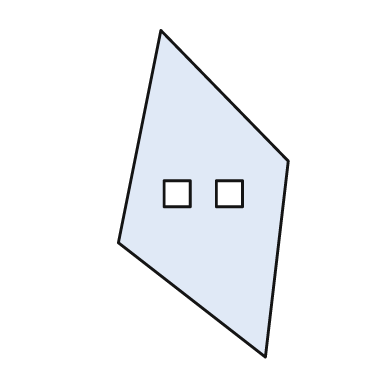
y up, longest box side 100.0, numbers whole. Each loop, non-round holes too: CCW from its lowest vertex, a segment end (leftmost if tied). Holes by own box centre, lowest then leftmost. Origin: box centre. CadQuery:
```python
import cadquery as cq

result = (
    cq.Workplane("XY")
    .moveTo(19.0, -50.0)
    .lineTo(26.0, 10.0)
    .lineTo(-13.0, 50.0)
    .lineTo(-26.0, -15.0)
    .close()
    .moveTo(-12.0, -4.0)
    .lineTo(-4.0, -4.0)
    .lineTo(-4.0, 4.0)
    .lineTo(-12.0, 4.0)
    .close()
    .moveTo(4.0, -4.0)
    .lineTo(12.0, -4.0)
    .lineTo(12.0, 4.0)
    .lineTo(4.0, 4.0)
    .close()
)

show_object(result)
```